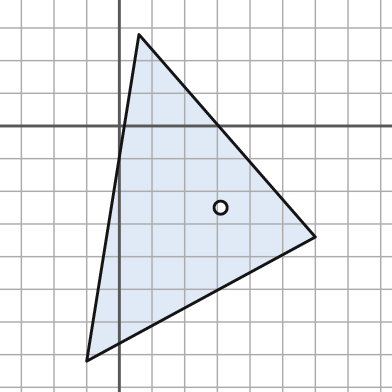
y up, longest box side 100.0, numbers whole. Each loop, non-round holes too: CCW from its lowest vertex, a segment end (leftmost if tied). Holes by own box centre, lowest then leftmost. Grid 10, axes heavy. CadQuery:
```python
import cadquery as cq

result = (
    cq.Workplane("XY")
    .moveTo(-10.0, -72.0)
    .lineTo(60.0, -34.0)
    .lineTo(6.0, 28.0)
    .close()
    .moveTo(31.0, -25.0)
    .circle(2.0)
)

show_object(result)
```